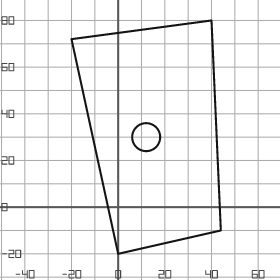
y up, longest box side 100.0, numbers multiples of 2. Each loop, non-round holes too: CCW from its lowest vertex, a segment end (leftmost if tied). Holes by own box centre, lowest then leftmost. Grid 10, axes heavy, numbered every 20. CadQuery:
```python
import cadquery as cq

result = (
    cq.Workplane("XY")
    .moveTo(0.0, -20.0)
    .lineTo(44.0, -10.0)
    .lineTo(40.0, 80.0)
    .lineTo(-20.0, 72.0)
    .close()
    .moveTo(12.0, 30.0)
    .circle(6.0)
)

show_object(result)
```